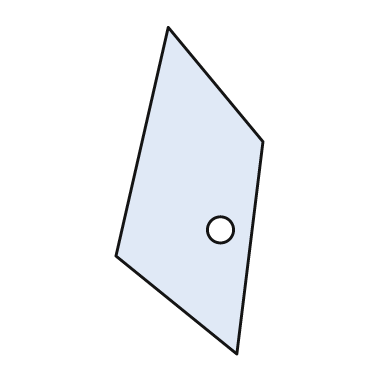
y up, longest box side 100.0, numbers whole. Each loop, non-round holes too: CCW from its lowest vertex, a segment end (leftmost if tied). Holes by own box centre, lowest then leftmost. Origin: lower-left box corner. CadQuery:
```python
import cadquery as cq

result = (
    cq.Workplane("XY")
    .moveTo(37.0, 0.0)
    .lineTo(45.0, 65.0)
    .lineTo(16.0, 100.0)
    .lineTo(0.0, 30.0)
    .close()
    .moveTo(32.0, 38.0)
    .circle(4.0)
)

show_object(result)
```